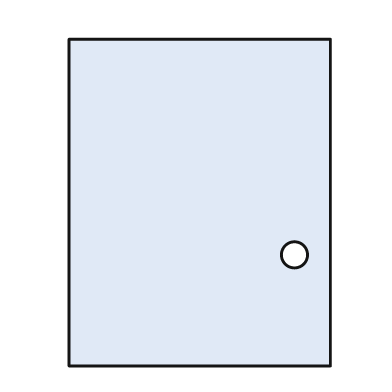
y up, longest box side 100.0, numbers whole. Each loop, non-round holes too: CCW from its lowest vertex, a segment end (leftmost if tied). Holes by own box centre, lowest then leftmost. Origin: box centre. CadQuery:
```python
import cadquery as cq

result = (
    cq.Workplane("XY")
    .moveTo(-40.0, -50.0)
    .lineTo(40.0, -50.0)
    .lineTo(40.0, 50.0)
    .lineTo(-40.0, 50.0)
    .close()
    .moveTo(29.0, -16.0)
    .circle(4.0)
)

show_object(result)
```